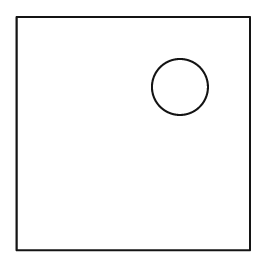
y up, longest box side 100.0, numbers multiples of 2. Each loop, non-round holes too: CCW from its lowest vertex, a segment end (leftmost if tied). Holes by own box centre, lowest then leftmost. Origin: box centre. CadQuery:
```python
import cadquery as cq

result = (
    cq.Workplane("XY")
    .moveTo(-50.0, -50.0)
    .lineTo(50.0, -50.0)
    .lineTo(50.0, 50.0)
    .lineTo(-50.0, 50.0)
    .close()
    .moveTo(20.0, 20.0)
    .circle(12.0)
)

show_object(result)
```